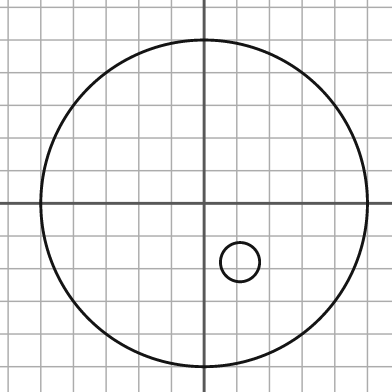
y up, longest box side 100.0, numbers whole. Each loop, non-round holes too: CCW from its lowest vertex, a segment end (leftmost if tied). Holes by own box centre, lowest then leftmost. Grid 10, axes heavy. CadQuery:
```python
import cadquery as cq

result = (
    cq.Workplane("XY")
    .moveTo(0.0, 0.0)
    .circle(50.0)
    .moveTo(11.0, -18.0)
    .circle(6.0)
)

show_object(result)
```